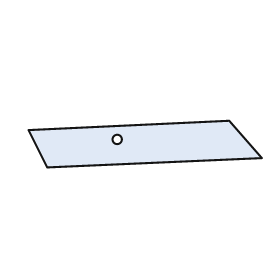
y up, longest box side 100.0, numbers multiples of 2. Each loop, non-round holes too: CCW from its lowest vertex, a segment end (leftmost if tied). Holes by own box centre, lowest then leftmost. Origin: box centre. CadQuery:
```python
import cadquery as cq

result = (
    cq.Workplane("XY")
    .moveTo(-42.0, -10.0)
    .lineTo(50.0, -6.0)
    .lineTo(36.0, 10.0)
    .lineTo(-50.0, 6.0)
    .close()
    .moveTo(-12.0, 2.0)
    .circle(2.0)
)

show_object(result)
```